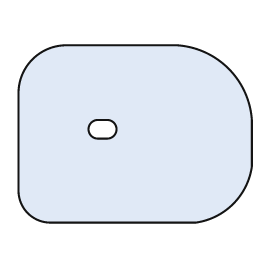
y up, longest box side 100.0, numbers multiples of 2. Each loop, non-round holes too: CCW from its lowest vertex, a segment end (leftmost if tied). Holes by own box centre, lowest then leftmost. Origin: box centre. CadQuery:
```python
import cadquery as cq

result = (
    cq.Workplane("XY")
    .moveTo(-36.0, -38.0)
    .lineTo(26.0, -38.0)
    .threePointArc((42.0, -30.0), (50.0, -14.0))
    .lineTo(50.0, 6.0)
    .threePointArc((40.0, 28.0), (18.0, 38.0))
    .lineTo(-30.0, 38.0)
    .threePointArc((-44.0, 32.0), (-50.0, 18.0))
    .lineTo(-50.0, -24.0)
    .threePointArc((-46.0, -34.0), (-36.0, -38.0))
    .close()
    .moveTo(-16.0, -2.0)
    .lineTo(-12.0, -2.0)
    .threePointArc((-8.0, 2.0), (-12.0, 6.0))
    .lineTo(-16.0, 6.0)
    .threePointArc((-20.0, 2.0), (-16.0, -2.0))
    .close()
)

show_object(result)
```